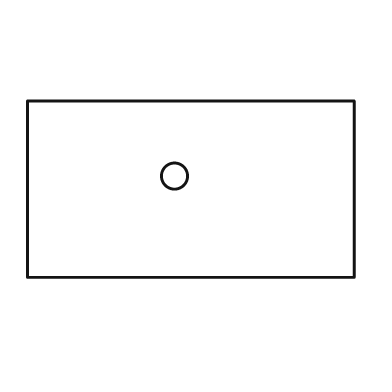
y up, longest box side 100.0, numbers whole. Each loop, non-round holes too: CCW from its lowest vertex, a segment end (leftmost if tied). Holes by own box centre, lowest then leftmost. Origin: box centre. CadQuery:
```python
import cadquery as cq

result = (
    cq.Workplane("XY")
    .moveTo(-50.0, -27.0)
    .lineTo(50.0, -27.0)
    .lineTo(50.0, 27.0)
    .lineTo(-50.0, 27.0)
    .close()
    .moveTo(-5.0, 4.0)
    .circle(4.0)
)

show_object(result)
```